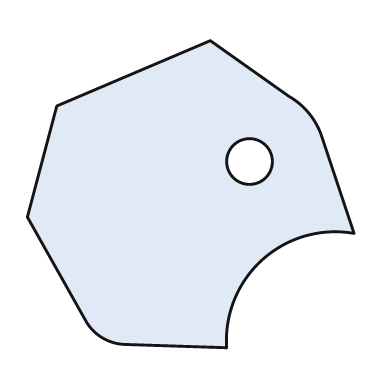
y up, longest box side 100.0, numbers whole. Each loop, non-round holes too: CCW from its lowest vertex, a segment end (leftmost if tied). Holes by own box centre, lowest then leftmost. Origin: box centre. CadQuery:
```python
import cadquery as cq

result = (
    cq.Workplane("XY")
    .moveTo(11.0, -47.0)
    .threePointArc((22.0, -20.0), (50.0, -12.0))
    .lineTo(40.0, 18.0)
    .threePointArc((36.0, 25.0), (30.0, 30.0))
    .lineTo(6.0, 47.0)
    .lineTo(-41.0, 27.0)
    .lineTo(-50.0, -7.0)
    .lineTo(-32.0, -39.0)
    .threePointArc((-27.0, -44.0), (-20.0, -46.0))
    .close()
    .moveTo(18.0, 10.0)
    .circle(7.0)
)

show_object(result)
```